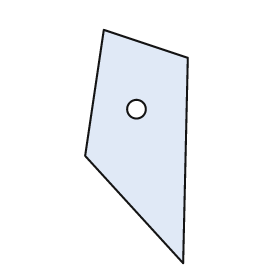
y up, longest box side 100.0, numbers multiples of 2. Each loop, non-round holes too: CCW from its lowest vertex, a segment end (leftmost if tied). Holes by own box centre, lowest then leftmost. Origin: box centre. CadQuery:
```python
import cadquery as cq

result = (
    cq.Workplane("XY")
    .moveTo(20.0, -50.0)
    .lineTo(22.0, 38.0)
    .lineTo(-14.0, 50.0)
    .lineTo(-22.0, -4.0)
    .close()
    .moveTo(0.0, 16.0)
    .circle(4.0)
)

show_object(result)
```